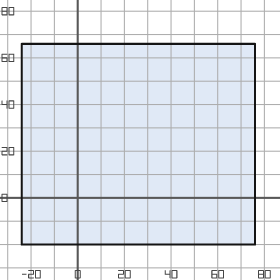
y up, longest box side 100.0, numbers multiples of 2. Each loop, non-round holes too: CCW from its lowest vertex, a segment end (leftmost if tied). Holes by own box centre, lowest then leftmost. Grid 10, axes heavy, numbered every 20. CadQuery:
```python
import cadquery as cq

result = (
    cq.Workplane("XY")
    .moveTo(-24.0, -20.0)
    .lineTo(76.0, -20.0)
    .lineTo(76.0, 66.0)
    .lineTo(-24.0, 66.0)
    .close()
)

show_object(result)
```